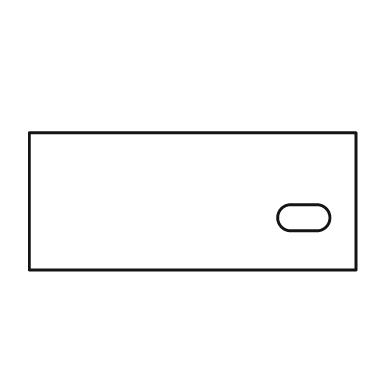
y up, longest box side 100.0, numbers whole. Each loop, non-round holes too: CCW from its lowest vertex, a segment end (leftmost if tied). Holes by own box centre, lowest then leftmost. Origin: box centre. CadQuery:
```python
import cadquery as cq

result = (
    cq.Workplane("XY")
    .moveTo(-50.0, -21.0)
    .lineTo(50.0, -21.0)
    .lineTo(50.0, 21.0)
    .lineTo(-50.0, 21.0)
    .close()
    .moveTo(30.0, -9.0)
    .lineTo(38.0, -9.0)
    .threePointArc((42.0, -5.0), (38.0, -1.0))
    .lineTo(30.0, -1.0)
    .threePointArc((26.0, -5.0), (30.0, -9.0))
    .close()
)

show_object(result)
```